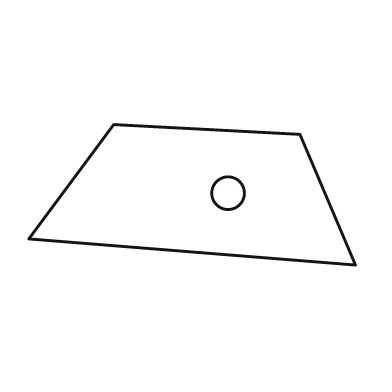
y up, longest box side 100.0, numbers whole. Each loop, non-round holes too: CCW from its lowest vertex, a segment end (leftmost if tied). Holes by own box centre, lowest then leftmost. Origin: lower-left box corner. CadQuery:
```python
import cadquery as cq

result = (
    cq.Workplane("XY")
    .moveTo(100.0, 0.0)
    .lineTo(83.0, 40.0)
    .lineTo(26.0, 43.0)
    .lineTo(0.0, 8.0)
    .close()
    .moveTo(61.0, 22.0)
    .circle(5.0)
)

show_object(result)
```